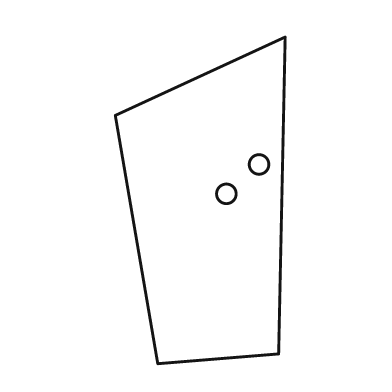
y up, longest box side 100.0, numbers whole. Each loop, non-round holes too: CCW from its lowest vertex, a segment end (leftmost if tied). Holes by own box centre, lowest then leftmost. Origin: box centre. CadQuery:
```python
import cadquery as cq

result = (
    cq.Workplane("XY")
    .moveTo(-13.0, -50.0)
    .lineTo(24.0, -47.0)
    .lineTo(26.0, 50.0)
    .lineTo(-26.0, 26.0)
    .close()
    .moveTo(8.0, 2.0)
    .circle(3.0)
    .moveTo(18.0, 11.0)
    .circle(3.0)
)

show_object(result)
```